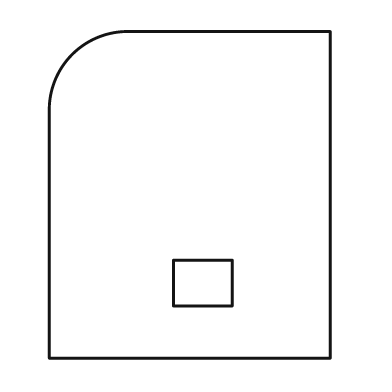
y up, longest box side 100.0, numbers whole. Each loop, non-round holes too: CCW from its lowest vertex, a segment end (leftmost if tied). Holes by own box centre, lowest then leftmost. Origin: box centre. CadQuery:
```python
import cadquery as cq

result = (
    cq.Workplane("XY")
    .moveTo(-43.0, -50.0)
    .lineTo(43.0, -50.0)
    .lineTo(43.0, 50.0)
    .lineTo(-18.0, 50.0)
    .threePointArc((-36.0, 43.0), (-43.0, 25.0))
    .close()
    .moveTo(-5.0, -34.0)
    .lineTo(13.0, -34.0)
    .lineTo(13.0, -20.0)
    .lineTo(-5.0, -20.0)
    .close()
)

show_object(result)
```